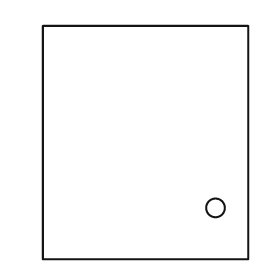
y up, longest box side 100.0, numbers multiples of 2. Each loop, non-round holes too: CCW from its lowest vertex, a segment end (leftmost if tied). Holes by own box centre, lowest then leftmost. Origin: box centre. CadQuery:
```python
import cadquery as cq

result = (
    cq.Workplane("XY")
    .moveTo(-44.0, -50.0)
    .lineTo(44.0, -50.0)
    .lineTo(44.0, 50.0)
    .lineTo(-44.0, 50.0)
    .close()
    .moveTo(30.0, -28.0)
    .circle(4.0)
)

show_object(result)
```